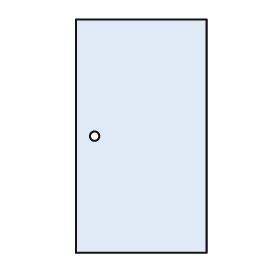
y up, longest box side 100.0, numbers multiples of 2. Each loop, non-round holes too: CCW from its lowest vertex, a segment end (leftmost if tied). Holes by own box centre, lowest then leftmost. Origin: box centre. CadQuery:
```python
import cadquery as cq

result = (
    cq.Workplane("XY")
    .moveTo(-28.0, -50.0)
    .lineTo(28.0, -50.0)
    .lineTo(28.0, 50.0)
    .lineTo(-28.0, 50.0)
    .close()
    .moveTo(-20.0, 0.0)
    .circle(2.0)
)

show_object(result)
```